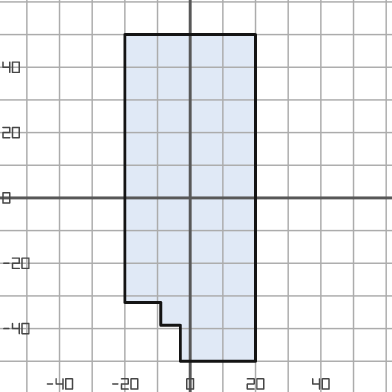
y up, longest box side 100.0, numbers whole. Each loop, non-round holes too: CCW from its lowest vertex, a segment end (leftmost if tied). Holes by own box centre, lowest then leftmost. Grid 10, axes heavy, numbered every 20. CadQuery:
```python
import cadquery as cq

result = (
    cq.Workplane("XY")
    .moveTo(-3.0, -50.0)
    .lineTo(20.0, -50.0)
    .lineTo(20.0, 50.0)
    .lineTo(-20.0, 50.0)
    .lineTo(-20.0, -32.0)
    .lineTo(-9.0, -32.0)
    .lineTo(-9.0, -39.0)
    .lineTo(-3.0, -39.0)
    .close()
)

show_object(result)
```